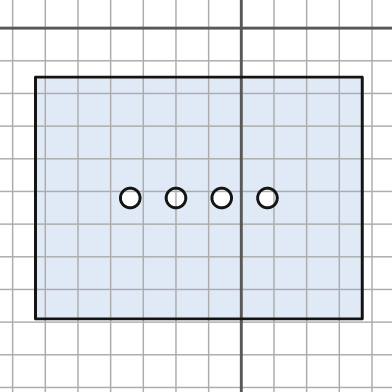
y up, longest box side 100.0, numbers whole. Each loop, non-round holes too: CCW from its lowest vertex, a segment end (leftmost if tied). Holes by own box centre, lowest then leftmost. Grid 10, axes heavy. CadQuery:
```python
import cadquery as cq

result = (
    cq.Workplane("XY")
    .moveTo(-63.0, -89.0)
    .lineTo(37.0, -89.0)
    .lineTo(37.0, -15.0)
    .lineTo(-63.0, -15.0)
    .close()
    .moveTo(-34.0, -52.0)
    .circle(3.0)
    .moveTo(-20.0, -52.0)
    .circle(3.0)
    .moveTo(-6.0, -52.0)
    .circle(3.0)
    .moveTo(8.0, -52.0)
    .circle(3.0)
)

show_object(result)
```